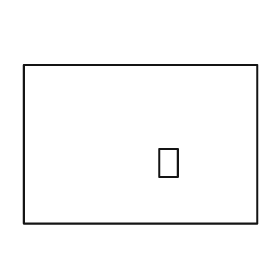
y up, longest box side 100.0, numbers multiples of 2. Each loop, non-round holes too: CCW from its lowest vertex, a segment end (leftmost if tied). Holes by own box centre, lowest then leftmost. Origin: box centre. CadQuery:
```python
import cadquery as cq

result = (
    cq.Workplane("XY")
    .moveTo(-50.0, -34.0)
    .lineTo(50.0, -34.0)
    .lineTo(50.0, 34.0)
    .lineTo(-50.0, 34.0)
    .close()
    .moveTo(8.0, -14.0)
    .lineTo(16.0, -14.0)
    .lineTo(16.0, -2.0)
    .lineTo(8.0, -2.0)
    .close()
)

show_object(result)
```